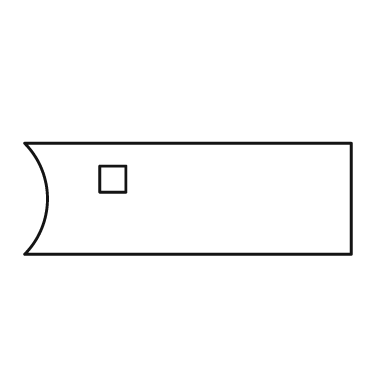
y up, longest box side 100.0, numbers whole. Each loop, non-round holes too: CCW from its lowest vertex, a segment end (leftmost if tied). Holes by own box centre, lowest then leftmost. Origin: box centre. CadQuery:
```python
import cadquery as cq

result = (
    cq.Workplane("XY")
    .moveTo(-50.0, -17.0)
    .lineTo(50.0, -17.0)
    .lineTo(50.0, 17.0)
    .lineTo(-50.0, 17.0)
    .threePointArc((-43.0, 0.0), (-50.0, -17.0))
    .close()
    .moveTo(-27.0, 2.0)
    .lineTo(-19.0, 2.0)
    .lineTo(-19.0, 10.0)
    .lineTo(-27.0, 10.0)
    .close()
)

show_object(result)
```